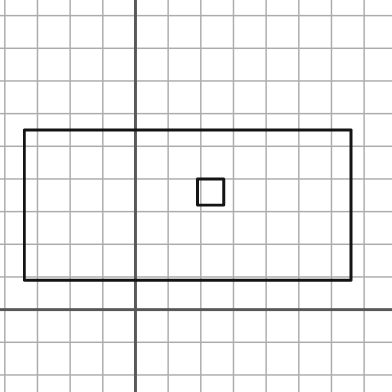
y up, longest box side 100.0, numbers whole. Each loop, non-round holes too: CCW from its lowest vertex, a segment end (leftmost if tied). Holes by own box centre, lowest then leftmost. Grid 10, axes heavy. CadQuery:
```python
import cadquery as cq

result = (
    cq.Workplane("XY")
    .moveTo(-34.0, 9.0)
    .lineTo(66.0, 9.0)
    .lineTo(66.0, 55.0)
    .lineTo(-34.0, 55.0)
    .close()
    .moveTo(19.0, 32.0)
    .lineTo(27.0, 32.0)
    .lineTo(27.0, 40.0)
    .lineTo(19.0, 40.0)
    .close()
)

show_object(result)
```